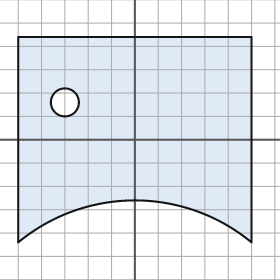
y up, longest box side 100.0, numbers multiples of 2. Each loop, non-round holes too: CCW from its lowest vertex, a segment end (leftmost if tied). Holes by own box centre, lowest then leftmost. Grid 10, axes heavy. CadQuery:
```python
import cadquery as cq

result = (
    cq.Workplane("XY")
    .moveTo(-50.0, -44.0)
    .threePointArc((0.0, -26.0), (50.0, -44.0))
    .lineTo(50.0, 44.0)
    .lineTo(-50.0, 44.0)
    .close()
    .moveTo(-30.0, 16.0)
    .circle(6.0)
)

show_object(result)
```